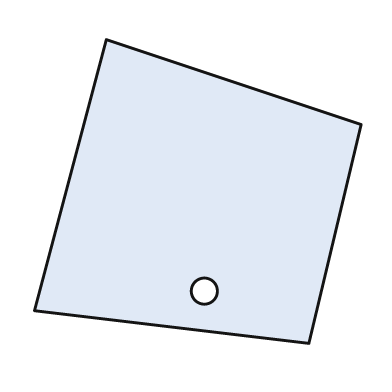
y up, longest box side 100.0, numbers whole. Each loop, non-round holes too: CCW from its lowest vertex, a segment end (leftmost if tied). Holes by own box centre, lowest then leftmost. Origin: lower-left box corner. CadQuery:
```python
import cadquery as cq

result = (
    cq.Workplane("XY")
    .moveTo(84.0, 0.0)
    .lineTo(100.0, 67.0)
    .lineTo(22.0, 93.0)
    .lineTo(0.0, 10.0)
    .close()
    .moveTo(52.0, 16.0)
    .circle(4.0)
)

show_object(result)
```